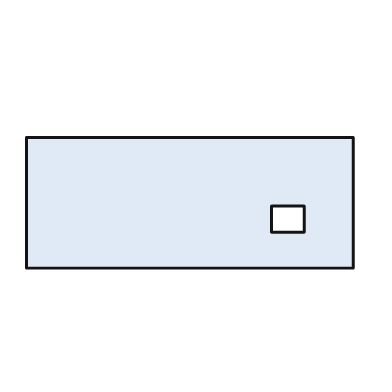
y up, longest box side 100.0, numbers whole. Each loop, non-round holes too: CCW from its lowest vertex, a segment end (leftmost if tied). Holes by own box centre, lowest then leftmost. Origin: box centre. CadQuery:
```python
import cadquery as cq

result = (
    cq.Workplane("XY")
    .moveTo(-50.0, -20.0)
    .lineTo(50.0, -20.0)
    .lineTo(50.0, 20.0)
    .lineTo(-50.0, 20.0)
    .close()
    .moveTo(25.0, -9.0)
    .lineTo(35.0, -9.0)
    .lineTo(35.0, -1.0)
    .lineTo(25.0, -1.0)
    .close()
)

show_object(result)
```